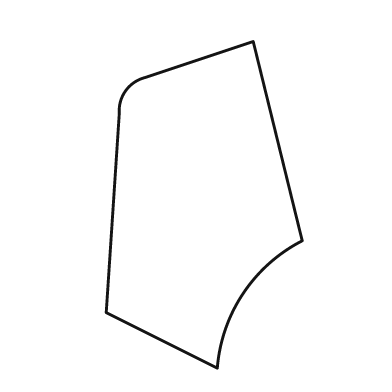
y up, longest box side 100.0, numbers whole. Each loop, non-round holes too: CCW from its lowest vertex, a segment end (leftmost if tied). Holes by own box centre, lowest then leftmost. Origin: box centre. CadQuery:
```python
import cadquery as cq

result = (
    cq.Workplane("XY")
    .moveTo(4.0, -50.0)
    .threePointArc((12.0, -27.0), (30.0, -11.0))
    .lineTo(15.0, 50.0)
    .lineTo(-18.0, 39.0)
    .threePointArc((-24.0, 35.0), (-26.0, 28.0))
    .lineTo(-30.0, -33.0)
    .close()
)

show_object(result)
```